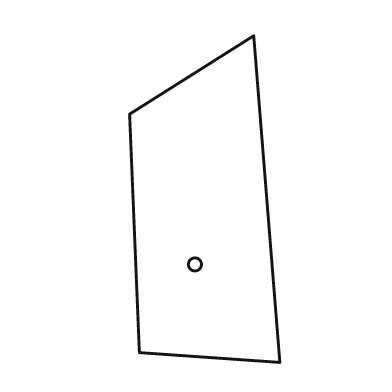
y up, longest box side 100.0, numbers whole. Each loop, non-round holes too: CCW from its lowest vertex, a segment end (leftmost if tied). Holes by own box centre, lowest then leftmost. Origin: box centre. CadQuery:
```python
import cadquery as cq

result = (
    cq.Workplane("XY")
    .moveTo(23.0, -50.0)
    .lineTo(15.0, 50.0)
    .lineTo(-23.0, 26.0)
    .lineTo(-20.0, -47.0)
    .close()
    .moveTo(-3.0, -20.0)
    .circle(2.0)
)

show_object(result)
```